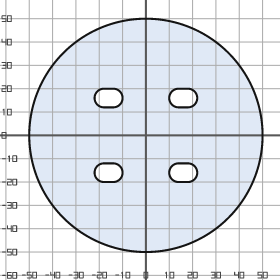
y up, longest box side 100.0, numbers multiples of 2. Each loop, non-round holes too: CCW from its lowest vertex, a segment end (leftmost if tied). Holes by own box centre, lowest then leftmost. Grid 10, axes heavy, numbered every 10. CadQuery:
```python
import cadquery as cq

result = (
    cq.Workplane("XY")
    .moveTo(0.0, 0.0)
    .circle(50.0)
    .moveTo(-18.0, -20.0)
    .lineTo(-14.0, -20.0)
    .threePointArc((-10.0, -16.0), (-14.0, -12.0))
    .lineTo(-18.0, -12.0)
    .threePointArc((-22.0, -16.0), (-18.0, -20.0))
    .close()
    .moveTo(14.0, -20.0)
    .lineTo(18.0, -20.0)
    .threePointArc((22.0, -16.0), (18.0, -12.0))
    .lineTo(14.0, -12.0)
    .threePointArc((10.0, -16.0), (14.0, -20.0))
    .close()
    .moveTo(-18.0, 12.0)
    .lineTo(-14.0, 12.0)
    .threePointArc((-10.0, 16.0), (-14.0, 20.0))
    .lineTo(-18.0, 20.0)
    .threePointArc((-22.0, 16.0), (-18.0, 12.0))
    .close()
    .moveTo(14.0, 12.0)
    .lineTo(18.0, 12.0)
    .threePointArc((22.0, 16.0), (18.0, 20.0))
    .lineTo(14.0, 20.0)
    .threePointArc((10.0, 16.0), (14.0, 12.0))
    .close()
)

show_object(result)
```